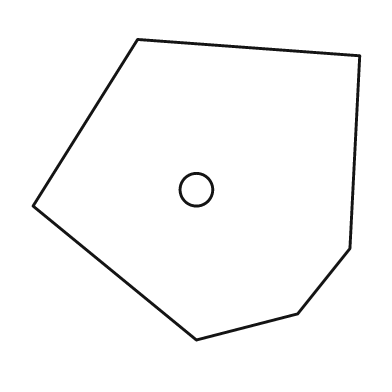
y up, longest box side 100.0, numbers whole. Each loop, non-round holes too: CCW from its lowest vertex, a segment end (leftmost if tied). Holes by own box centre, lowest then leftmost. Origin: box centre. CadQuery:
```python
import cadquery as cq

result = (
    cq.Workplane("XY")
    .moveTo(0.0, -46.0)
    .lineTo(31.0, -38.0)
    .lineTo(47.0, -18.0)
    .lineTo(50.0, 41.0)
    .lineTo(-18.0, 46.0)
    .lineTo(-50.0, -5.0)
    .close()
    .moveTo(0.0, 0.0)
    .circle(5.0)
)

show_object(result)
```